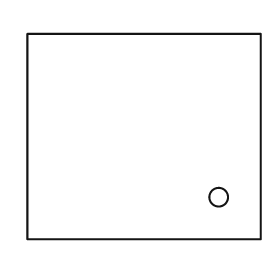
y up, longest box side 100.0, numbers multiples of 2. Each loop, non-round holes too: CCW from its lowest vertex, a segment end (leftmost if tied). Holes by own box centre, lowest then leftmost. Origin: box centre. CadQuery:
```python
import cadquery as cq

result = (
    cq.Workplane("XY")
    .moveTo(-50.0, -44.0)
    .lineTo(50.0, -44.0)
    .lineTo(50.0, 44.0)
    .lineTo(-50.0, 44.0)
    .close()
    .moveTo(32.0, -26.0)
    .circle(4.0)
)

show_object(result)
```